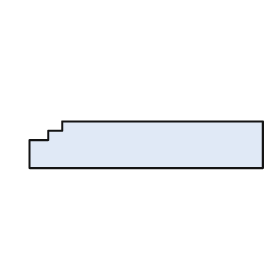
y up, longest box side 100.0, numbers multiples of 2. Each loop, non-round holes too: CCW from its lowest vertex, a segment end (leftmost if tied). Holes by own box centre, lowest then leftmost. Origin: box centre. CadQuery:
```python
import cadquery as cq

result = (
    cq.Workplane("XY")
    .moveTo(-50.0, -10.0)
    .lineTo(50.0, -10.0)
    .lineTo(50.0, 10.0)
    .lineTo(-36.0, 10.0)
    .lineTo(-36.0, 6.0)
    .lineTo(-42.0, 6.0)
    .lineTo(-42.0, 2.0)
    .lineTo(-50.0, 2.0)
    .close()
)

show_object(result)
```